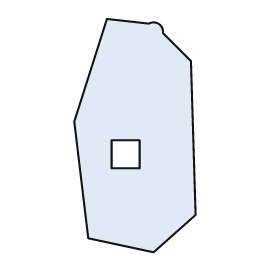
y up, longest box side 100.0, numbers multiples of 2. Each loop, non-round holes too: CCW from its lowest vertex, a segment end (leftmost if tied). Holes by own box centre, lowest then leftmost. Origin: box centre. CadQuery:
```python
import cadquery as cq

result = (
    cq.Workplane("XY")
    .moveTo(8.0, -50.0)
    .lineTo(26.0, -34.0)
    .lineTo(24.0, 32.0)
    .lineTo(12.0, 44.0)
    .threePointArc((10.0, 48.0), (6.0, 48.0))
    .lineTo(-12.0, 50.0)
    .lineTo(-26.0, 6.0)
    .lineTo(-20.0, -44.0)
    .close()
    .moveTo(-10.0, -14.0)
    .lineTo(2.0, -14.0)
    .lineTo(2.0, -2.0)
    .lineTo(-10.0, -2.0)
    .close()
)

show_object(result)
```